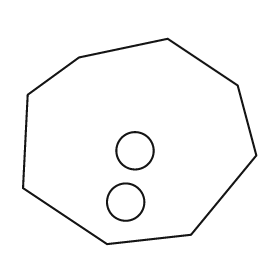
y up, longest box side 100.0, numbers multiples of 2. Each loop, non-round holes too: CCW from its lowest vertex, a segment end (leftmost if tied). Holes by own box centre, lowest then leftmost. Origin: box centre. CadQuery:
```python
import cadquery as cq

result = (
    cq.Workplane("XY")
    .moveTo(-14.0, -44.0)
    .lineTo(22.0, -40.0)
    .lineTo(50.0, -6.0)
    .lineTo(42.0, 24.0)
    .lineTo(12.0, 44.0)
    .lineTo(-26.0, 36.0)
    .lineTo(-48.0, 20.0)
    .lineTo(-50.0, -20.0)
    .close()
    .moveTo(-6.0, -26.0)
    .circle(8.0)
    .moveTo(-2.0, -4.0)
    .circle(8.0)
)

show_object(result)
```